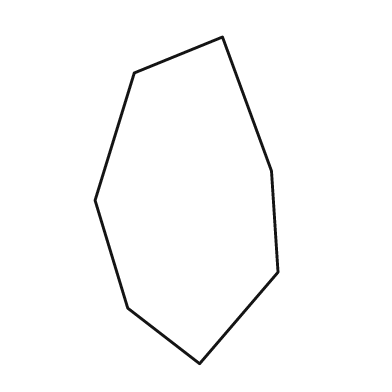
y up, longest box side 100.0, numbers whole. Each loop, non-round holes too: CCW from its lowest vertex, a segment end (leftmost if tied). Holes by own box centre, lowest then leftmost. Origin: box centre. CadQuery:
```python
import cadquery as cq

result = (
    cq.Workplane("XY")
    .moveTo(4.0, -50.0)
    .lineTo(28.0, -22.0)
    .lineTo(26.0, 9.0)
    .lineTo(11.0, 50.0)
    .lineTo(-16.0, 39.0)
    .lineTo(-28.0, 0.0)
    .lineTo(-18.0, -33.0)
    .close()
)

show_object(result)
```